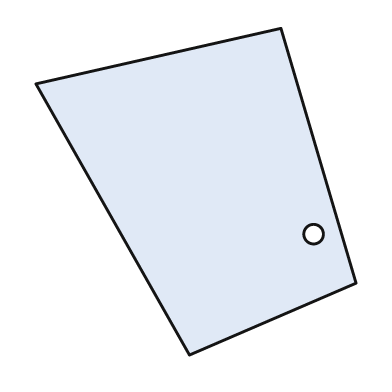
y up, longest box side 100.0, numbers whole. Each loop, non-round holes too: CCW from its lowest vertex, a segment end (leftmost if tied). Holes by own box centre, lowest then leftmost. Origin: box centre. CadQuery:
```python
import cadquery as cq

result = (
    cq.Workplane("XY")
    .moveTo(-2.0, -50.0)
    .lineTo(49.0, -28.0)
    .lineTo(26.0, 50.0)
    .lineTo(-49.0, 33.0)
    .close()
    .moveTo(36.0, -13.0)
    .circle(3.0)
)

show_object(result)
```